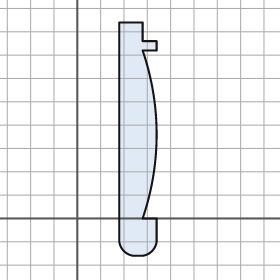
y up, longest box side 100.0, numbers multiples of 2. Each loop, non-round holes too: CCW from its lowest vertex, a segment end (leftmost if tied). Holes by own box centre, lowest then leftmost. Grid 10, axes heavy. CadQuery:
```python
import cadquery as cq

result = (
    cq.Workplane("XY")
    .moveTo(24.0, -16.0)
    .lineTo(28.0, -16.0)
    .threePointArc((32.0, -14.0), (34.0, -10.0))
    .lineTo(34.0, 0.0)
    .lineTo(28.0, 0.0)
    .threePointArc((34.0, 36.0), (28.0, 72.0))
    .lineTo(34.0, 72.0)
    .lineTo(34.0, 76.0)
    .lineTo(28.0, 76.0)
    .lineTo(28.0, 84.0)
    .lineTo(18.0, 84.0)
    .lineTo(18.0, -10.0)
    .threePointArc((20.0, -14.0), (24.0, -16.0))
    .close()
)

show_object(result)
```